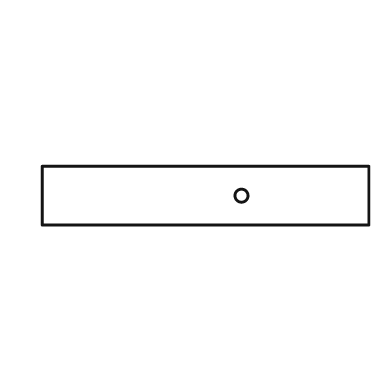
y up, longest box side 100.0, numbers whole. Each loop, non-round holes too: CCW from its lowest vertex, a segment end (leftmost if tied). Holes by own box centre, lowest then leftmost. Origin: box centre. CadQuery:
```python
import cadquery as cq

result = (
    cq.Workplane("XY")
    .moveTo(-50.0, -9.0)
    .lineTo(50.0, -9.0)
    .lineTo(50.0, 9.0)
    .lineTo(-50.0, 9.0)
    .close()
    .moveTo(11.0, 0.0)
    .circle(2.0)
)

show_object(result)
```